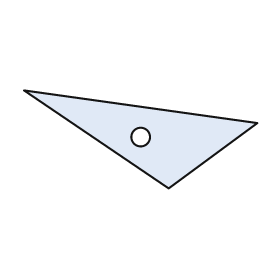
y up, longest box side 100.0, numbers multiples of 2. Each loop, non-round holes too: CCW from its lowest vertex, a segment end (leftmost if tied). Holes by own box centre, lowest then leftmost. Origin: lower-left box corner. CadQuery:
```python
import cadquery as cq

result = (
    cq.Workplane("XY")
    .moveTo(62.0, 0.0)
    .lineTo(100.0, 28.0)
    .lineTo(0.0, 42.0)
    .close()
    .moveTo(50.0, 22.0)
    .circle(4.0)
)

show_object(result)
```